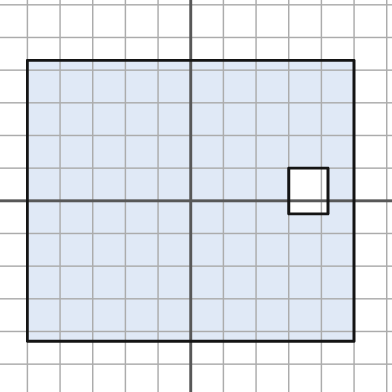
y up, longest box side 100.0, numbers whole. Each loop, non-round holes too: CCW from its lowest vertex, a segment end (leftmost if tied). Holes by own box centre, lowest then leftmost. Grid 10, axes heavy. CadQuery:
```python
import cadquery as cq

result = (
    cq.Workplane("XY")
    .moveTo(-50.0, -43.0)
    .lineTo(50.0, -43.0)
    .lineTo(50.0, 43.0)
    .lineTo(-50.0, 43.0)
    .close()
    .moveTo(30.0, -4.0)
    .lineTo(42.0, -4.0)
    .lineTo(42.0, 10.0)
    .lineTo(30.0, 10.0)
    .close()
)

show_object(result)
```